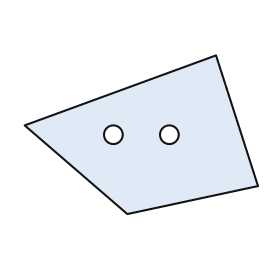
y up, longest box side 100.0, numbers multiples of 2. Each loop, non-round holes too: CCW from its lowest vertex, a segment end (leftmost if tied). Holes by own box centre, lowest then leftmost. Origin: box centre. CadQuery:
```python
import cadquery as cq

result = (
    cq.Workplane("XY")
    .moveTo(-6.0, -34.0)
    .lineTo(50.0, -22.0)
    .lineTo(32.0, 34.0)
    .lineTo(-50.0, 4.0)
    .close()
    .moveTo(-12.0, 0.0)
    .circle(4.0)
    .moveTo(12.0, 0.0)
    .circle(4.0)
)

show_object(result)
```